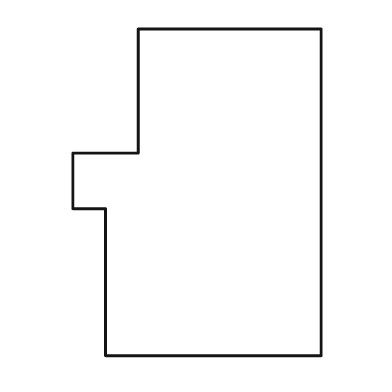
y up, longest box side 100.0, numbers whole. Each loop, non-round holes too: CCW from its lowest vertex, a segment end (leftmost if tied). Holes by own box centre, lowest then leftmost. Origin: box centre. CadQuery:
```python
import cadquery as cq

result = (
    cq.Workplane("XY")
    .moveTo(-28.0, -50.0)
    .lineTo(38.0, -50.0)
    .lineTo(38.0, 50.0)
    .lineTo(-18.0, 50.0)
    .lineTo(-18.0, 12.0)
    .lineTo(-38.0, 12.0)
    .lineTo(-38.0, -5.0)
    .lineTo(-28.0, -5.0)
    .close()
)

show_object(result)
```